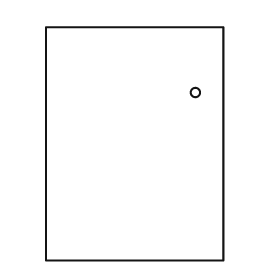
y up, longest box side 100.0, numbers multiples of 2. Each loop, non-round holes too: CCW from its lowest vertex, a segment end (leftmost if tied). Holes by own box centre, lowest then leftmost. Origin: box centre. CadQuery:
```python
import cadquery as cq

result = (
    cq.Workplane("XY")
    .moveTo(-38.0, -50.0)
    .lineTo(38.0, -50.0)
    .lineTo(38.0, 50.0)
    .lineTo(-38.0, 50.0)
    .close()
    .moveTo(26.0, 22.0)
    .circle(2.0)
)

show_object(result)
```